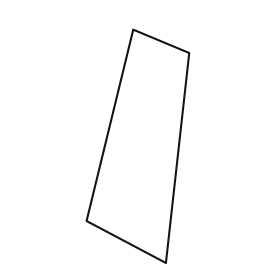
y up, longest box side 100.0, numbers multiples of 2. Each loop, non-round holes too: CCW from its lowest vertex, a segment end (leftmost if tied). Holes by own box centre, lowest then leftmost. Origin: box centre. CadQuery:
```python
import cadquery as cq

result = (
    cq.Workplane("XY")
    .moveTo(12.0, -50.0)
    .lineTo(22.0, 40.0)
    .lineTo(-2.0, 50.0)
    .lineTo(-22.0, -32.0)
    .close()
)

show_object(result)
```